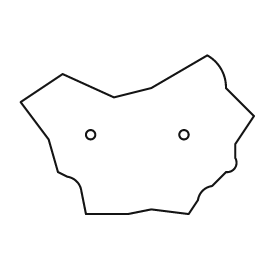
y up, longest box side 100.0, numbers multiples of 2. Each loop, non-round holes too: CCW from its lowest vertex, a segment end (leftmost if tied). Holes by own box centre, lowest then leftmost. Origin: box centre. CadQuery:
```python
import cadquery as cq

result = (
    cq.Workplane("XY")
    .moveTo(-22.0, -34.0)
    .lineTo(-4.0, -34.0)
    .lineTo(6.0, -32.0)
    .lineTo(22.0, -34.0)
    .lineTo(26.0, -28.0)
    .threePointArc((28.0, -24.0), (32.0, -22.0))
    .lineTo(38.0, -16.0)
    .threePointArc((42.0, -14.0), (42.0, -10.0))
    .lineTo(42.0, -4.0)
    .lineTo(50.0, 8.0)
    .lineTo(38.0, 20.0)
    .threePointArc((36.0, 28.0), (30.0, 34.0))
    .lineTo(6.0, 20.0)
    .lineTo(-10.0, 16.0)
    .lineTo(-32.0, 26.0)
    .lineTo(-50.0, 14.0)
    .lineTo(-38.0, -2.0)
    .lineTo(-34.0, -16.0)
    .lineTo(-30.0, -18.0)
    .threePointArc((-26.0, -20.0), (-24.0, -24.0))
    .close()
    .moveTo(-20.0, 0.0)
    .circle(2.0)
    .moveTo(20.0, 0.0)
    .circle(2.0)
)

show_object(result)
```